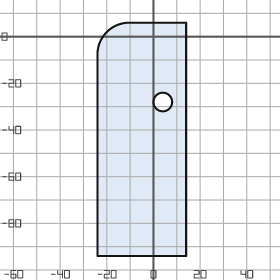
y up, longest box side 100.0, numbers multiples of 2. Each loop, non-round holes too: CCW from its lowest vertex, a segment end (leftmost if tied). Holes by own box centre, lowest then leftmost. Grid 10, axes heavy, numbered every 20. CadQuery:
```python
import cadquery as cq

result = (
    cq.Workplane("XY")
    .moveTo(-24.0, -94.0)
    .lineTo(14.0, -94.0)
    .lineTo(14.0, 6.0)
    .lineTo(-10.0, 6.0)
    .threePointArc((-20.0, 2.0), (-24.0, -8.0))
    .close()
    .moveTo(4.0, -28.0)
    .circle(4.0)
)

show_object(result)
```